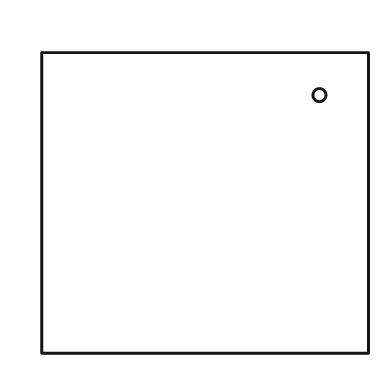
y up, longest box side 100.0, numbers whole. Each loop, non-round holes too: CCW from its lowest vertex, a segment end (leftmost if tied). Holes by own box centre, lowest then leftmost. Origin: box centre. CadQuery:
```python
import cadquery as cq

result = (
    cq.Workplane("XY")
    .moveTo(-50.0, -46.0)
    .lineTo(50.0, -46.0)
    .lineTo(50.0, 46.0)
    .lineTo(-50.0, 46.0)
    .close()
    .moveTo(35.0, 33.0)
    .circle(2.0)
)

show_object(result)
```